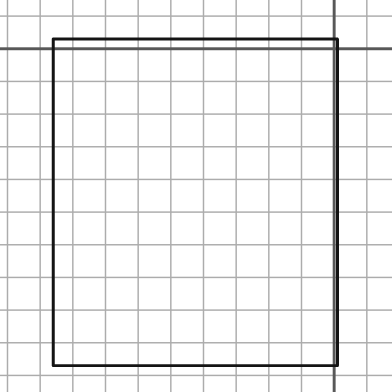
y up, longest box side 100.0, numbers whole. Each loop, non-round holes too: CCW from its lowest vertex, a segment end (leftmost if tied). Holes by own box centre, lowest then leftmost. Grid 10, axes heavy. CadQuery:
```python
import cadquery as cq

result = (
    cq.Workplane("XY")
    .moveTo(-86.0, -97.0)
    .lineTo(1.0, -97.0)
    .lineTo(1.0, 3.0)
    .lineTo(-86.0, 3.0)
    .close()
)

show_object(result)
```